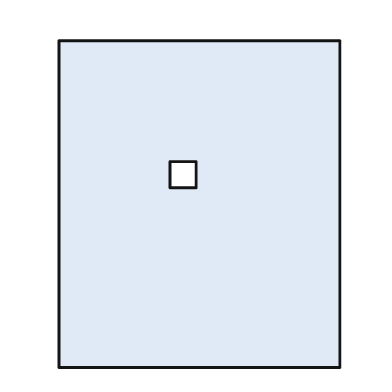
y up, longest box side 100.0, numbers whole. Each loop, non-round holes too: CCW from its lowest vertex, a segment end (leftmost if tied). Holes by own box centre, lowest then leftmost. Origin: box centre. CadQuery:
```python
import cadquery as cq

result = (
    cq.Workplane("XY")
    .moveTo(-43.0, -50.0)
    .lineTo(43.0, -50.0)
    .lineTo(43.0, 50.0)
    .lineTo(-43.0, 50.0)
    .close()
    .moveTo(-9.0, 5.0)
    .lineTo(-1.0, 5.0)
    .lineTo(-1.0, 13.0)
    .lineTo(-9.0, 13.0)
    .close()
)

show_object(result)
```